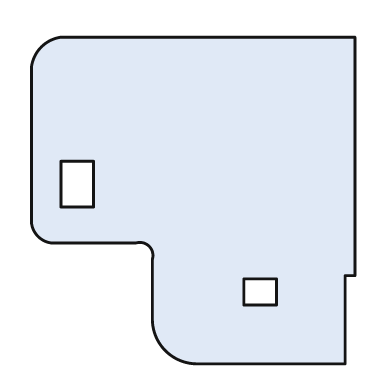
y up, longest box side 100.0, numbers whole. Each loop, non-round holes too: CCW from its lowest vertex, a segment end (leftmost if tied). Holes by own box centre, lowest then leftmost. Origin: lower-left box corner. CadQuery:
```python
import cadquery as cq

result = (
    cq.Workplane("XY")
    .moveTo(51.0, 0.0)
    .lineTo(96.0, 0.0)
    .lineTo(96.0, 27.0)
    .lineTo(99.0, 27.0)
    .lineTo(99.0, 100.0)
    .lineTo(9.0, 100.0)
    .threePointArc((3.0, 97.0), (0.0, 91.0))
    .lineTo(0.0, 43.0)
    .threePointArc((2.0, 39.0), (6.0, 37.0))
    .lineTo(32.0, 37.0)
    .threePointArc((36.0, 36.0), (37.0, 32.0))
    .lineTo(37.0, 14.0)
    .threePointArc((41.0, 4.0), (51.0, 0.0))
    .close()
    .moveTo(65.0, 18.0)
    .lineTo(75.0, 18.0)
    .lineTo(75.0, 26.0)
    .lineTo(65.0, 26.0)
    .close()
    .moveTo(9.0, 48.0)
    .lineTo(19.0, 48.0)
    .lineTo(19.0, 62.0)
    .lineTo(9.0, 62.0)
    .close()
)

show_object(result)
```